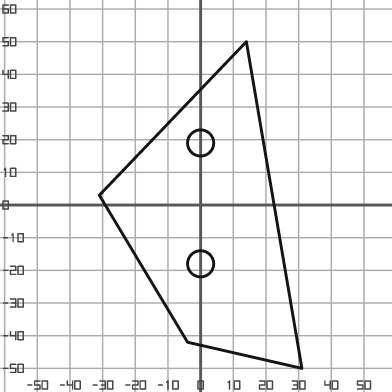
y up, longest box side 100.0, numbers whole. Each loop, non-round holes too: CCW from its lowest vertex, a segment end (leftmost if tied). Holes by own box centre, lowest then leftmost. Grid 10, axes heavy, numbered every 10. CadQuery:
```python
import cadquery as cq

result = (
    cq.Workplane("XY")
    .moveTo(31.0, -50.0)
    .lineTo(14.0, 50.0)
    .lineTo(-31.0, 3.0)
    .lineTo(-4.0, -42.0)
    .close()
    .moveTo(0.0, -18.0)
    .circle(4.0)
    .moveTo(0.0, 19.0)
    .circle(4.0)
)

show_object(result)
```